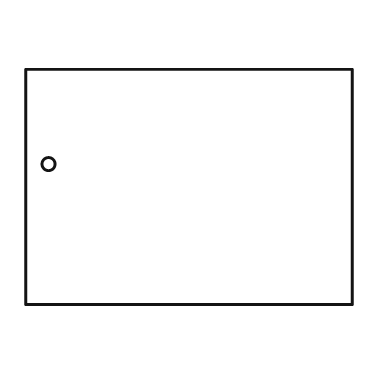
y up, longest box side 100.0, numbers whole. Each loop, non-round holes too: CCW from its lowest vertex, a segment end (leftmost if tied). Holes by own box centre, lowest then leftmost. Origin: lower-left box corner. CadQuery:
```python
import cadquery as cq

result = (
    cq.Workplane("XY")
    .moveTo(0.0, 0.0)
    .lineTo(100.0, 0.0)
    .lineTo(100.0, 72.0)
    .lineTo(0.0, 72.0)
    .close()
    .moveTo(7.0, 43.0)
    .circle(2.0)
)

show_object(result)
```